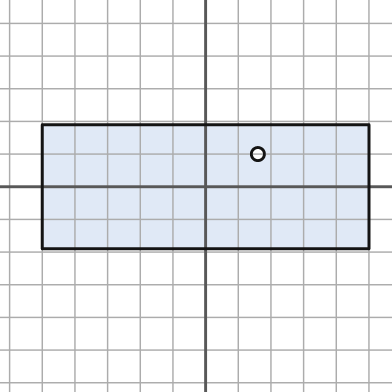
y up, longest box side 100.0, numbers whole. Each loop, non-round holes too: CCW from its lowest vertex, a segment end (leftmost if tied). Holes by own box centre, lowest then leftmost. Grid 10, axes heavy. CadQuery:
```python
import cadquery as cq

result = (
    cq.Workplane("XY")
    .moveTo(-50.0, -19.0)
    .lineTo(50.0, -19.0)
    .lineTo(50.0, 19.0)
    .lineTo(-50.0, 19.0)
    .close()
    .moveTo(16.0, 10.0)
    .circle(2.0)
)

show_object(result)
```